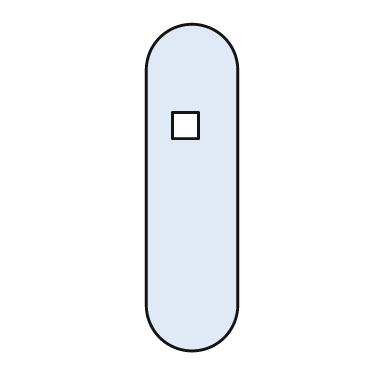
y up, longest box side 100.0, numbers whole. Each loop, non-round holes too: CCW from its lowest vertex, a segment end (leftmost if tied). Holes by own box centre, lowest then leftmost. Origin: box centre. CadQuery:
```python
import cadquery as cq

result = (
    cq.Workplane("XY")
    .moveTo(-14.0, -36.0)
    .threePointArc((0.0, -50.0), (14.0, -36.0))
    .lineTo(14.0, 36.0)
    .threePointArc((0.0, 50.0), (-14.0, 36.0))
    .close()
    .moveTo(-6.0, 15.0)
    .lineTo(2.0, 15.0)
    .lineTo(2.0, 23.0)
    .lineTo(-6.0, 23.0)
    .close()
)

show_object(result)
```